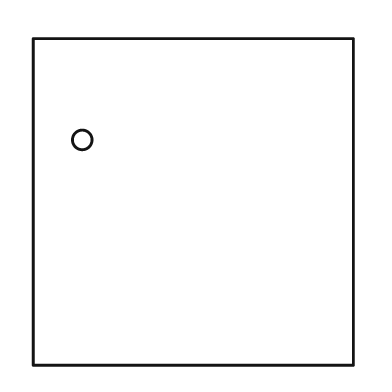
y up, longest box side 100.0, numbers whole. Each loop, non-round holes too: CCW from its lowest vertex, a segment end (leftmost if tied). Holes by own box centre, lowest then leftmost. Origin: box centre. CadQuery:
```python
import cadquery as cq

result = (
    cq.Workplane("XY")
    .moveTo(-49.0, -50.0)
    .lineTo(49.0, -50.0)
    .lineTo(49.0, 50.0)
    .lineTo(-49.0, 50.0)
    .close()
    .moveTo(-34.0, 19.0)
    .circle(3.0)
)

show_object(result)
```